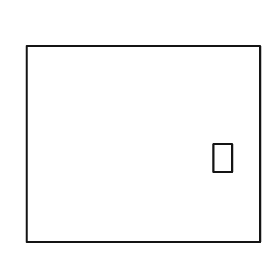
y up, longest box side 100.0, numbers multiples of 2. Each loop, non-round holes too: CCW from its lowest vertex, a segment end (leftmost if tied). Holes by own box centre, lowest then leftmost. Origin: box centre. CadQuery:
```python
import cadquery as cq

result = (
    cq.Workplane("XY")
    .moveTo(-50.0, -42.0)
    .lineTo(50.0, -42.0)
    .lineTo(50.0, 42.0)
    .lineTo(-50.0, 42.0)
    .close()
    .moveTo(30.0, -12.0)
    .lineTo(38.0, -12.0)
    .lineTo(38.0, 0.0)
    .lineTo(30.0, 0.0)
    .close()
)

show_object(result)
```